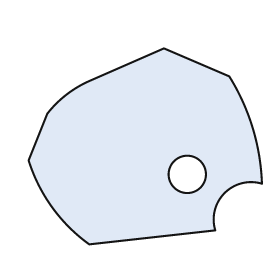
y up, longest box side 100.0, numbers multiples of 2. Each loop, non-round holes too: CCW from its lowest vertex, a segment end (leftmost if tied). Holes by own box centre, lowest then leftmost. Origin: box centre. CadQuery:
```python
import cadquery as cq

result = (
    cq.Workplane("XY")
    .moveTo(-24.0, -42.0)
    .lineTo(30.0, -36.0)
    .threePointArc((34.0, -20.0), (50.0, -16.0))
    .threePointArc((46.0, 8.0), (36.0, 30.0))
    .lineTo(8.0, 42.0)
    .lineTo(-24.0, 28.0)
    .threePointArc((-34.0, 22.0), (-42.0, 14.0))
    .lineTo(-50.0, -6.0)
    .threePointArc((-40.0, -26.0), (-24.0, -42.0))
    .close()
    .moveTo(18.0, -12.0)
    .circle(8.0)
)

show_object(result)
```